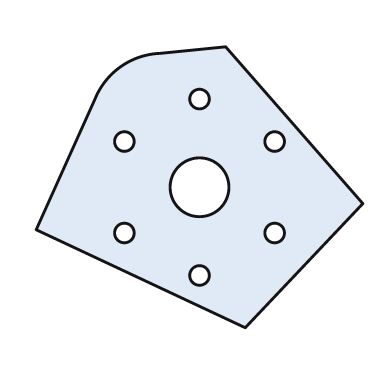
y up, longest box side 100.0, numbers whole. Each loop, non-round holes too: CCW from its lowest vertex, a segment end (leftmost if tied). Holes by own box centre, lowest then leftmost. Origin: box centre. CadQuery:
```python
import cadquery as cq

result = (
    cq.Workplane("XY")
    .moveTo(14.0, -43.0)
    .lineTo(50.0, -5.0)
    .lineTo(8.0, 43.0)
    .lineTo(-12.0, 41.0)
    .threePointArc((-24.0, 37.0), (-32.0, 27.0))
    .lineTo(-50.0, -13.0)
    .close()
    .moveTo(0.0, -27.0)
    .circle(3.0)
    .moveTo(-23.0, -14.0)
    .circle(3.0)
    .moveTo(23.0, -14.0)
    .circle(3.0)
    .moveTo(0.0, 0.0)
    .circle(9.0)
    .moveTo(-23.0, 14.0)
    .circle(3.0)
    .moveTo(23.0, 14.0)
    .circle(3.0)
    .moveTo(0.0, 27.0)
    .circle(3.0)
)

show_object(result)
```